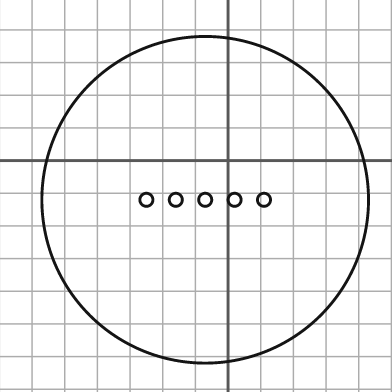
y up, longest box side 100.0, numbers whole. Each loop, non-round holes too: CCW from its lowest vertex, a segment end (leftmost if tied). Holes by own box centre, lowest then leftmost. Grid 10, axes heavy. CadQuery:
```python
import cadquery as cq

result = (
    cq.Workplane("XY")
    .moveTo(-7.0, -12.0)
    .circle(50.0)
    .moveTo(-25.0, -12.0)
    .circle(2.0)
    .moveTo(-16.0, -12.0)
    .circle(2.0)
    .moveTo(-7.0, -12.0)
    .circle(2.0)
    .moveTo(2.0, -12.0)
    .circle(2.0)
    .moveTo(11.0, -12.0)
    .circle(2.0)
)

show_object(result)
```